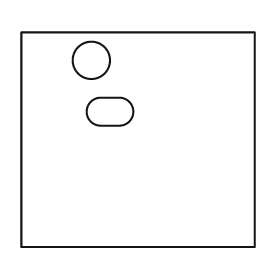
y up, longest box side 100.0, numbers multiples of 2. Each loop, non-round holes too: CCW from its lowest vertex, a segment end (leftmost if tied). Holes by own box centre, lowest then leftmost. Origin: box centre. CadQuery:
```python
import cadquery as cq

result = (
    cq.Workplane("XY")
    .moveTo(-50.0, -46.0)
    .lineTo(50.0, -46.0)
    .lineTo(50.0, 46.0)
    .lineTo(-50.0, 46.0)
    .close()
    .moveTo(-16.0, 6.0)
    .lineTo(-8.0, 6.0)
    .threePointArc((-2.0, 12.0), (-8.0, 18.0))
    .lineTo(-16.0, 18.0)
    .threePointArc((-22.0, 12.0), (-16.0, 6.0))
    .close()
    .moveTo(-20.0, 34.0)
    .circle(8.0)
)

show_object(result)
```